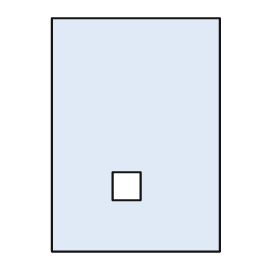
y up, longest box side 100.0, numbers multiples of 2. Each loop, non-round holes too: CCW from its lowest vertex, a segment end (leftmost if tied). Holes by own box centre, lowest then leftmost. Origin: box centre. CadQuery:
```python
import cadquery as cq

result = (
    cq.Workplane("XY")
    .moveTo(-36.0, -50.0)
    .lineTo(36.0, -50.0)
    .lineTo(36.0, 50.0)
    .lineTo(-36.0, 50.0)
    .close()
    .moveTo(-10.0, -28.0)
    .lineTo(2.0, -28.0)
    .lineTo(2.0, -16.0)
    .lineTo(-10.0, -16.0)
    .close()
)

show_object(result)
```